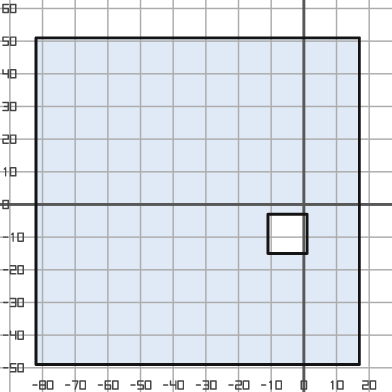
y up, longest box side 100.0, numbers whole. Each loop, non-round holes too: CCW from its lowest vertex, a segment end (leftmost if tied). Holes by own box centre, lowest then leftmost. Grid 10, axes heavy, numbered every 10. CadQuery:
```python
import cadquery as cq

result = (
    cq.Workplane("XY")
    .moveTo(-82.0, -49.0)
    .lineTo(17.0, -49.0)
    .lineTo(17.0, 51.0)
    .lineTo(-82.0, 51.0)
    .close()
    .moveTo(-11.0, -15.0)
    .lineTo(1.0, -15.0)
    .lineTo(1.0, -3.0)
    .lineTo(-11.0, -3.0)
    .close()
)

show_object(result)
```